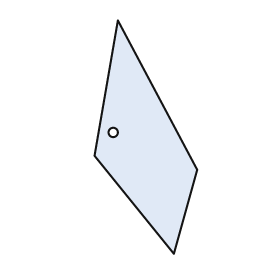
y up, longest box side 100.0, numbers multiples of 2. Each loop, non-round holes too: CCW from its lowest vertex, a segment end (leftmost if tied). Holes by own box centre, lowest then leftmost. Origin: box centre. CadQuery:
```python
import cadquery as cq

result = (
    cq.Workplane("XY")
    .moveTo(12.0, -50.0)
    .lineTo(22.0, -14.0)
    .lineTo(-12.0, 50.0)
    .lineTo(-22.0, -8.0)
    .close()
    .moveTo(-14.0, 2.0)
    .circle(2.0)
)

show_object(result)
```